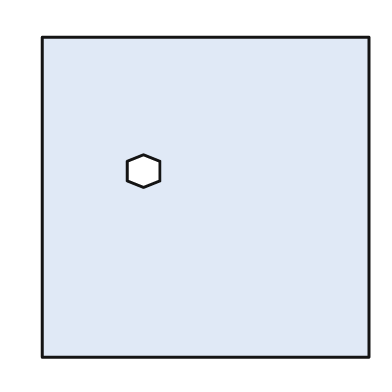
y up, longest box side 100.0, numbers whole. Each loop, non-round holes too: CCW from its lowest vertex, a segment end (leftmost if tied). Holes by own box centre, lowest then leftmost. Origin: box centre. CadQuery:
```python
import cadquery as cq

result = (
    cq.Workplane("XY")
    .moveTo(-50.0, -49.0)
    .lineTo(50.0, -49.0)
    .lineTo(50.0, 49.0)
    .lineTo(-50.0, 49.0)
    .close()
    .moveTo(-19.0, 3.0)
    .lineTo(-14.0, 5.0)
    .lineTo(-14.0, 11.0)
    .lineTo(-19.0, 13.0)
    .lineTo(-24.0, 11.0)
    .lineTo(-24.0, 5.0)
    .close()
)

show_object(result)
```